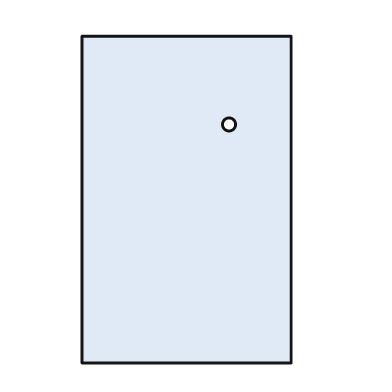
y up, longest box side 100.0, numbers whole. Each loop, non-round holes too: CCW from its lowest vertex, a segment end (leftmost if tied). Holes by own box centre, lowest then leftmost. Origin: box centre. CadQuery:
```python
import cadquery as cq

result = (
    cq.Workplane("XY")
    .moveTo(-32.0, -50.0)
    .lineTo(32.0, -50.0)
    .lineTo(32.0, 50.0)
    .lineTo(-32.0, 50.0)
    .close()
    .moveTo(13.0, 23.0)
    .circle(2.0)
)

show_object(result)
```